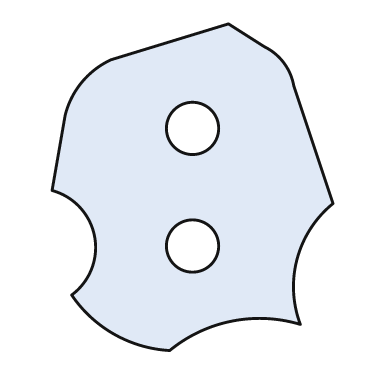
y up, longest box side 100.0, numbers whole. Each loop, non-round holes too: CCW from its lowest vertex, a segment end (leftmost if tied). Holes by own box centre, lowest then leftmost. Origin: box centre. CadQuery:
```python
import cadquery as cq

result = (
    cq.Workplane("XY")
    .moveTo(-7.0, -50.0)
    .threePointArc((12.0, -41.0), (33.0, -42.0))
    .threePointArc((32.0, -22.0), (43.0, -5.0))
    .lineTo(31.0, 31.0)
    .threePointArc((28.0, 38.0), (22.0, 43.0))
    .lineTo(11.0, 50.0)
    .lineTo(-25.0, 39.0)
    .threePointArc((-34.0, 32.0), (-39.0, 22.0))
    .lineTo(-43.0, -1.0)
    .threePointArc((-30.0, -15.0), (-37.0, -33.0))
    .threePointArc((-24.0, -45.0), (-7.0, -50.0))
    .close()
    .moveTo(0.0, -18.0)
    .circle(8.0)
    .moveTo(0.0, 18.0)
    .circle(8.0)
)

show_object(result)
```